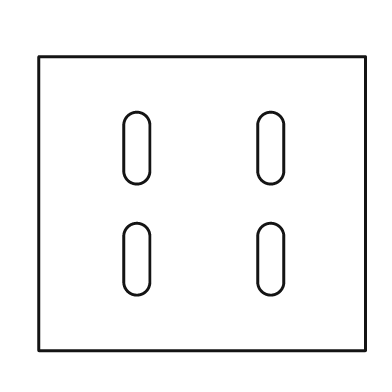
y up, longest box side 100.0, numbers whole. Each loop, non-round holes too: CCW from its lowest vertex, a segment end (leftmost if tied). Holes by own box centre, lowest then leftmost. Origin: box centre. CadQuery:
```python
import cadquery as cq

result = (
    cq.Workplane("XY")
    .moveTo(-50.0, -45.0)
    .lineTo(50.0, -45.0)
    .lineTo(50.0, 45.0)
    .lineTo(-50.0, 45.0)
    .close()
    .moveTo(-24.0, -24.0)
    .threePointArc((-20.0, -28.0), (-16.0, -24.0))
    .lineTo(-16.0, -10.0)
    .threePointArc((-20.0, -6.0), (-24.0, -10.0))
    .close()
    .moveTo(17.0, -24.0)
    .threePointArc((21.0, -28.0), (25.0, -24.0))
    .lineTo(25.0, -10.0)
    .threePointArc((21.0, -6.0), (17.0, -10.0))
    .close()
    .moveTo(-24.0, 10.0)
    .threePointArc((-20.0, 6.0), (-16.0, 10.0))
    .lineTo(-16.0, 24.0)
    .threePointArc((-20.0, 28.0), (-24.0, 24.0))
    .close()
    .moveTo(17.0, 10.0)
    .threePointArc((21.0, 6.0), (25.0, 10.0))
    .lineTo(25.0, 24.0)
    .threePointArc((21.0, 28.0), (17.0, 24.0))
    .close()
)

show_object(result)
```